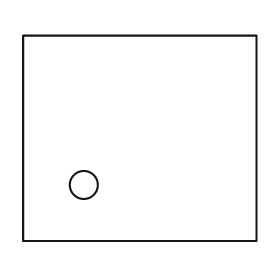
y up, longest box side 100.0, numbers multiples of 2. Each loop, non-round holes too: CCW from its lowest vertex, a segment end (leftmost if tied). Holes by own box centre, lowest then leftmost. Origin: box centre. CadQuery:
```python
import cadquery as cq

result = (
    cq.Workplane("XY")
    .moveTo(-50.0, -44.0)
    .lineTo(50.0, -44.0)
    .lineTo(50.0, 44.0)
    .lineTo(-50.0, 44.0)
    .close()
    .moveTo(-24.0, -20.0)
    .circle(6.0)
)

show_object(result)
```